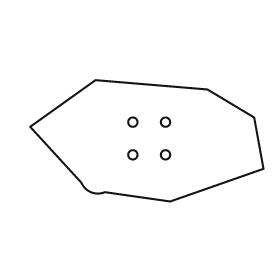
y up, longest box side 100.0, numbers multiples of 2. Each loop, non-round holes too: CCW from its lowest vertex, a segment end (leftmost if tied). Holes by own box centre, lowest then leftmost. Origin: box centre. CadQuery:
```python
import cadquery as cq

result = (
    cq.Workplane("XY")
    .moveTo(10.0, -26.0)
    .lineTo(50.0, -12.0)
    .lineTo(46.0, 10.0)
    .lineTo(26.0, 22.0)
    .lineTo(-22.0, 26.0)
    .lineTo(-50.0, 6.0)
    .lineTo(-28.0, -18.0)
    .threePointArc((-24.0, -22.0), (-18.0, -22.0))
    .close()
    .moveTo(-6.0, -6.0)
    .circle(2.0)
    .moveTo(8.0, -6.0)
    .circle(2.0)
    .moveTo(-6.0, 8.0)
    .circle(2.0)
    .moveTo(8.0, 8.0)
    .circle(2.0)
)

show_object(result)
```